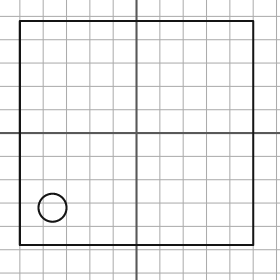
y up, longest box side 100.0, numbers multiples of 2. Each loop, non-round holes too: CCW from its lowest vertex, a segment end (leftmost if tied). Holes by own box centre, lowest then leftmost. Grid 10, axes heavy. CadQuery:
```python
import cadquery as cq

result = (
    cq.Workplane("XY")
    .moveTo(-50.0, -48.0)
    .lineTo(50.0, -48.0)
    .lineTo(50.0, 48.0)
    .lineTo(-50.0, 48.0)
    .close()
    .moveTo(-36.0, -32.0)
    .circle(6.0)
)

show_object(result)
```